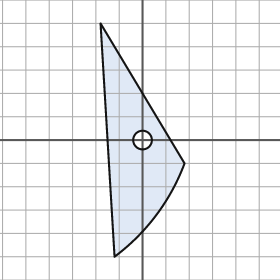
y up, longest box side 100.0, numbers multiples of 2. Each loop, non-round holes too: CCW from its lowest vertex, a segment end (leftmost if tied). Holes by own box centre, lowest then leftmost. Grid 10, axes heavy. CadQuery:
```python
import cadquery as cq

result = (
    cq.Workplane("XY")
    .moveTo(-12.0, -50.0)
    .threePointArc((6.0, -32.0), (18.0, -10.0))
    .lineTo(-18.0, 50.0)
    .close()
    .moveTo(0.0, 0.0)
    .circle(4.0)
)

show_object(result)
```